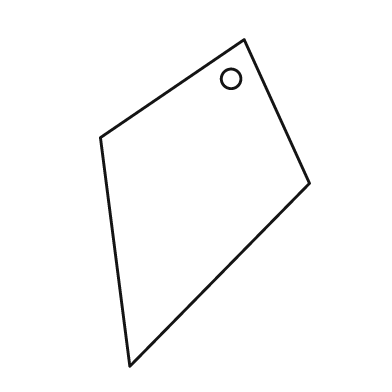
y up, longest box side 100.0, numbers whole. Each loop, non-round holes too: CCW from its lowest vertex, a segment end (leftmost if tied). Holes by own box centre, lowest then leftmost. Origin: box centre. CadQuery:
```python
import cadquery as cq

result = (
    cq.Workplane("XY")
    .moveTo(-23.0, -50.0)
    .lineTo(32.0, 6.0)
    .lineTo(12.0, 50.0)
    .lineTo(-32.0, 20.0)
    .close()
    .moveTo(8.0, 38.0)
    .circle(3.0)
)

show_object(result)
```